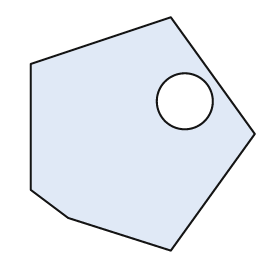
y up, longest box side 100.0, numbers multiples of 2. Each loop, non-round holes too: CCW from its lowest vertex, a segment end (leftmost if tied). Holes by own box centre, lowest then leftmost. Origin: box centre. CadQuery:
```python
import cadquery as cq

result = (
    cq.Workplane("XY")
    .moveTo(12.0, -50.0)
    .lineTo(48.0, 0.0)
    .lineTo(12.0, 50.0)
    .lineTo(-48.0, 30.0)
    .lineTo(-48.0, -24.0)
    .lineTo(-32.0, -36.0)
    .close()
    .moveTo(18.0, 14.0)
    .circle(12.0)
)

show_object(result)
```